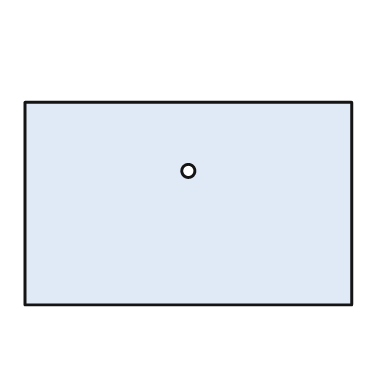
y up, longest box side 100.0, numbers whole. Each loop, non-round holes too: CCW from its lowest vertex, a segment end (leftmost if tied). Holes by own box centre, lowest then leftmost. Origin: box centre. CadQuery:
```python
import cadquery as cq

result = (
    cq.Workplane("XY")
    .moveTo(-50.0, -31.0)
    .lineTo(50.0, -31.0)
    .lineTo(50.0, 31.0)
    .lineTo(-50.0, 31.0)
    .close()
    .moveTo(0.0, 10.0)
    .circle(2.0)
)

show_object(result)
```